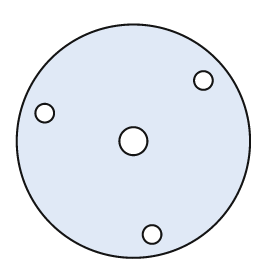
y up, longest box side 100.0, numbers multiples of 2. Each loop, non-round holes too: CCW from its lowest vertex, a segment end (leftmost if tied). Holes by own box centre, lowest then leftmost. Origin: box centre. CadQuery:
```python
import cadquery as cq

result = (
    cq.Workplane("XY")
    .moveTo(0.0, 0.0)
    .circle(50.0)
    .moveTo(8.0, -40.0)
    .circle(4.0)
    .moveTo(0.0, 0.0)
    .circle(6.0)
    .moveTo(-38.0, 12.0)
    .circle(4.0)
    .moveTo(30.0, 26.0)
    .circle(4.0)
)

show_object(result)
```